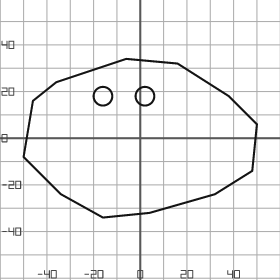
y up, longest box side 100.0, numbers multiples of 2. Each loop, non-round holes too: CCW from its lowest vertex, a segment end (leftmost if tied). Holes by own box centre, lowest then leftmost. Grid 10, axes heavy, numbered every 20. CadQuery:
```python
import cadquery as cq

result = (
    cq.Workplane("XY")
    .moveTo(-16.0, -34.0)
    .lineTo(4.0, -32.0)
    .lineTo(32.0, -24.0)
    .lineTo(48.0, -14.0)
    .lineTo(50.0, 6.0)
    .lineTo(38.0, 18.0)
    .lineTo(16.0, 32.0)
    .lineTo(-6.0, 34.0)
    .lineTo(-36.0, 24.0)
    .lineTo(-46.0, 16.0)
    .lineTo(-50.0, -8.0)
    .lineTo(-34.0, -24.0)
    .close()
    .moveTo(-16.0, 18.0)
    .circle(4.0)
    .moveTo(2.0, 18.0)
    .circle(4.0)
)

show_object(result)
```